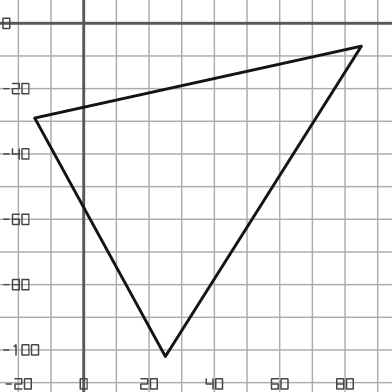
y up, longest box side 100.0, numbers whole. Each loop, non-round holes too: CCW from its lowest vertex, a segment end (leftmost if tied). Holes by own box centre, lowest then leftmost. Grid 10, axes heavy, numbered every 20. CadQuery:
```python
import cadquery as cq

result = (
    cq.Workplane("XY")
    .moveTo(25.0, -102.0)
    .lineTo(85.0, -7.0)
    .lineTo(-15.0, -29.0)
    .close()
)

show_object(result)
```